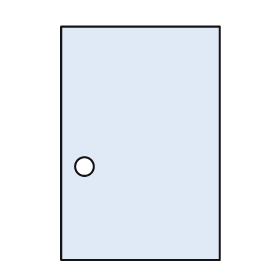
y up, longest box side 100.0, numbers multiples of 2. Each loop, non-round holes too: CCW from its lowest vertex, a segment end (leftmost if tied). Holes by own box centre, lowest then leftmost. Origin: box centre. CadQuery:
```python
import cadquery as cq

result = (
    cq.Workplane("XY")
    .moveTo(-34.0, -50.0)
    .lineTo(34.0, -50.0)
    .lineTo(34.0, 50.0)
    .lineTo(-34.0, 50.0)
    .close()
    .moveTo(-24.0, -10.0)
    .circle(4.0)
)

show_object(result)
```